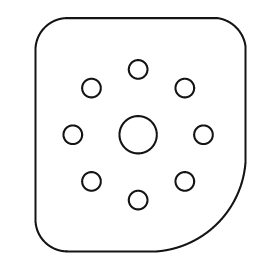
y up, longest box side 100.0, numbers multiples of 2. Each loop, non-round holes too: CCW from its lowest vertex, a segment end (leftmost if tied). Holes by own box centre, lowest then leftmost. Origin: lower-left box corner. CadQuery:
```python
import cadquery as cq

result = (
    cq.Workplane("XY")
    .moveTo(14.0, 0.0)
    .lineTo(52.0, 0.0)
    .threePointArc((78.0, 12.0), (90.0, 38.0))
    .lineTo(90.0, 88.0)
    .threePointArc((86.0, 96.0), (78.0, 100.0))
    .lineTo(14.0, 100.0)
    .threePointArc((4.0, 96.0), (0.0, 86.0))
    .lineTo(0.0, 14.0)
    .threePointArc((4.0, 4.0), (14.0, 0.0))
    .close()
    .moveTo(44.0, 22.0)
    .circle(4.0)
    .moveTo(24.0, 30.0)
    .circle(4.0)
    .moveTo(64.0, 30.0)
    .circle(4.0)
    .moveTo(16.0, 50.0)
    .circle(4.0)
    .moveTo(44.0, 50.0)
    .circle(8.0)
    .moveTo(72.0, 50.0)
    .circle(4.0)
    .moveTo(24.0, 70.0)
    .circle(4.0)
    .moveTo(64.0, 70.0)
    .circle(4.0)
    .moveTo(44.0, 78.0)
    .circle(4.0)
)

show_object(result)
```